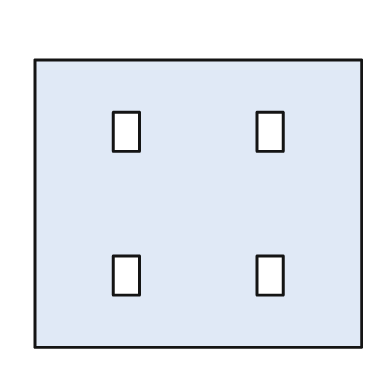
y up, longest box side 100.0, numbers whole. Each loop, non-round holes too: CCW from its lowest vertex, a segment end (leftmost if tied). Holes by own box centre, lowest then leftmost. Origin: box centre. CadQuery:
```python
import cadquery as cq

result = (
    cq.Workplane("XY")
    .moveTo(-50.0, -44.0)
    .lineTo(50.0, -44.0)
    .lineTo(50.0, 44.0)
    .lineTo(-50.0, 44.0)
    .close()
    .moveTo(-26.0, -28.0)
    .lineTo(-18.0, -28.0)
    .lineTo(-18.0, -16.0)
    .lineTo(-26.0, -16.0)
    .close()
    .moveTo(18.0, -28.0)
    .lineTo(26.0, -28.0)
    .lineTo(26.0, -16.0)
    .lineTo(18.0, -16.0)
    .close()
    .moveTo(-26.0, 16.0)
    .lineTo(-18.0, 16.0)
    .lineTo(-18.0, 28.0)
    .lineTo(-26.0, 28.0)
    .close()
    .moveTo(18.0, 16.0)
    .lineTo(26.0, 16.0)
    .lineTo(26.0, 28.0)
    .lineTo(18.0, 28.0)
    .close()
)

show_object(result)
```